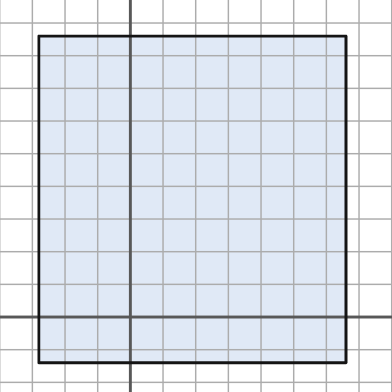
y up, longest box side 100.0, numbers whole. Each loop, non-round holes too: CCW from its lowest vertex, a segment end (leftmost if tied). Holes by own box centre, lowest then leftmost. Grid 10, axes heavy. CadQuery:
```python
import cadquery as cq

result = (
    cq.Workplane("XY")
    .moveTo(-28.0, -14.0)
    .lineTo(66.0, -14.0)
    .lineTo(66.0, 86.0)
    .lineTo(-28.0, 86.0)
    .close()
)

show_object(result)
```